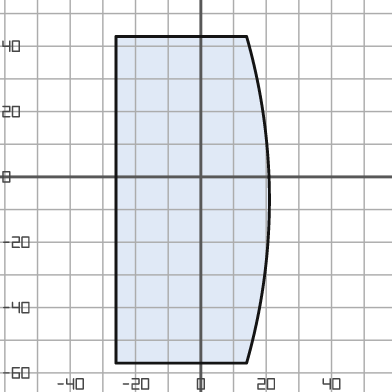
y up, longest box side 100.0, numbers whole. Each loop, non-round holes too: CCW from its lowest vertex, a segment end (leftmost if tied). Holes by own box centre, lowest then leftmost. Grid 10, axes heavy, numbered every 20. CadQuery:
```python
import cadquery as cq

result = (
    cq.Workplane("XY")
    .moveTo(-26.0, -57.0)
    .lineTo(14.0, -57.0)
    .threePointArc((21.0, -7.0), (14.0, 43.0))
    .lineTo(-26.0, 43.0)
    .close()
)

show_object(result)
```